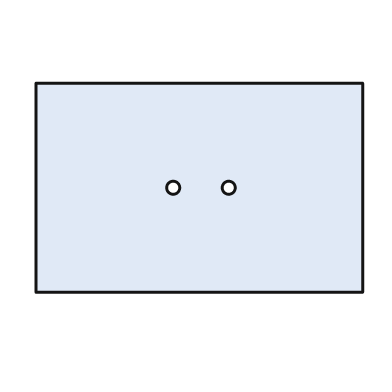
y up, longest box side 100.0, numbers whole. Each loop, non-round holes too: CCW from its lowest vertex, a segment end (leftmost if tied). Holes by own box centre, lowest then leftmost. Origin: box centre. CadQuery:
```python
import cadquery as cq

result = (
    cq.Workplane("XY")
    .moveTo(-50.0, -32.0)
    .lineTo(50.0, -32.0)
    .lineTo(50.0, 32.0)
    .lineTo(-50.0, 32.0)
    .close()
    .moveTo(-8.0, 0.0)
    .circle(2.0)
    .moveTo(9.0, 0.0)
    .circle(2.0)
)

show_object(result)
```